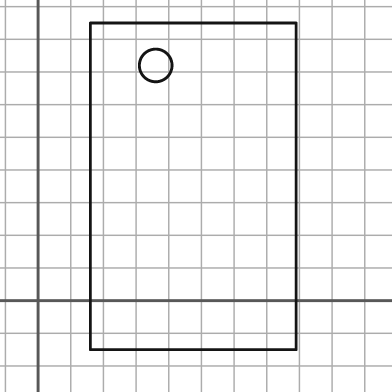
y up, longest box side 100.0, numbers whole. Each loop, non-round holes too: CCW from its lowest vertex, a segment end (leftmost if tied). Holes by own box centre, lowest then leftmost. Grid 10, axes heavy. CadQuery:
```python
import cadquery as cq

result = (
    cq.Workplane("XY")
    .moveTo(16.0, -15.0)
    .lineTo(79.0, -15.0)
    .lineTo(79.0, 85.0)
    .lineTo(16.0, 85.0)
    .close()
    .moveTo(36.0, 72.0)
    .circle(5.0)
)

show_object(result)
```